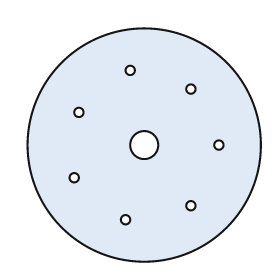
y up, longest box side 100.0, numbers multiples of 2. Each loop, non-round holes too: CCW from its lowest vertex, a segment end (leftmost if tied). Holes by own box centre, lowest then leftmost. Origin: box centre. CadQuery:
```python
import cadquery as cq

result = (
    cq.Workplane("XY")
    .moveTo(0.0, 0.0)
    .circle(50.0)
    .moveTo(-8.0, -32.0)
    .circle(2.0)
    .moveTo(20.0, -26.0)
    .circle(2.0)
    .moveTo(-30.0, -14.0)
    .circle(2.0)
    .moveTo(0.0, 0.0)
    .circle(6.0)
    .moveTo(32.0, 0.0)
    .circle(2.0)
    .moveTo(-28.0, 14.0)
    .circle(2.0)
    .moveTo(20.0, 24.0)
    .circle(2.0)
    .moveTo(-6.0, 32.0)
    .circle(2.0)
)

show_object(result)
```